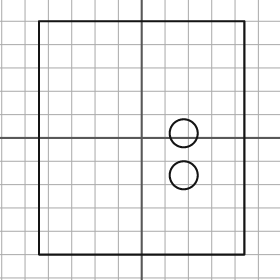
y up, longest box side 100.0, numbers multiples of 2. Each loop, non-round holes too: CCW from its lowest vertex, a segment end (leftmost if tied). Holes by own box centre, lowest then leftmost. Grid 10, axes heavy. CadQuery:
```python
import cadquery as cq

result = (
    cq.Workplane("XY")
    .moveTo(-44.0, -50.0)
    .lineTo(44.0, -50.0)
    .lineTo(44.0, 50.0)
    .lineTo(-44.0, 50.0)
    .close()
    .moveTo(18.0, -16.0)
    .circle(6.0)
    .moveTo(18.0, 2.0)
    .circle(6.0)
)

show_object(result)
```